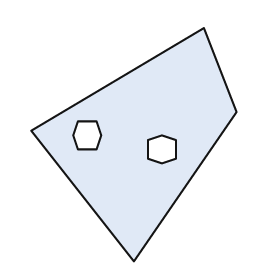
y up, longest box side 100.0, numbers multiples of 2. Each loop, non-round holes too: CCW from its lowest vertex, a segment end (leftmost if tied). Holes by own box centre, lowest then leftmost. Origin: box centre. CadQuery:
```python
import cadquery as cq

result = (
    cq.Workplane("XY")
    .moveTo(0.0, -50.0)
    .lineTo(44.0, 14.0)
    .lineTo(30.0, 50.0)
    .lineTo(-44.0, 6.0)
    .close()
    .moveTo(12.0, -8.0)
    .lineTo(18.0, -6.0)
    .lineTo(18.0, 2.0)
    .lineTo(12.0, 4.0)
    .lineTo(6.0, 2.0)
    .lineTo(6.0, -6.0)
    .close()
    .moveTo(-24.0, -2.0)
    .lineTo(-16.0, -2.0)
    .lineTo(-14.0, 4.0)
    .lineTo(-16.0, 10.0)
    .lineTo(-24.0, 10.0)
    .lineTo(-26.0, 4.0)
    .close()
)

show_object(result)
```